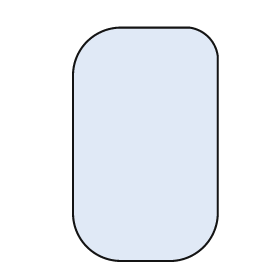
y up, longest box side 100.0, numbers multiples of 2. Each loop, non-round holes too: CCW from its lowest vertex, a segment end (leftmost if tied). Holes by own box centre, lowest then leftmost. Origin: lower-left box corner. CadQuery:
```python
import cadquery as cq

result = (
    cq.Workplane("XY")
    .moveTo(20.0, 0.0)
    .lineTo(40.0, 0.0)
    .threePointArc((56.0, 6.0), (62.0, 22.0))
    .lineTo(62.0, 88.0)
    .threePointArc((58.0, 96.0), (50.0, 100.0))
    .lineTo(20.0, 100.0)
    .threePointArc((6.0, 94.0), (0.0, 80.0))
    .lineTo(0.0, 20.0)
    .threePointArc((6.0, 6.0), (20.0, 0.0))
    .close()
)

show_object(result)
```